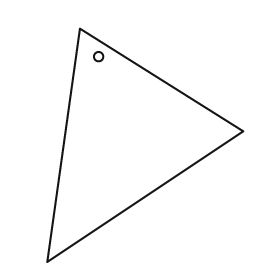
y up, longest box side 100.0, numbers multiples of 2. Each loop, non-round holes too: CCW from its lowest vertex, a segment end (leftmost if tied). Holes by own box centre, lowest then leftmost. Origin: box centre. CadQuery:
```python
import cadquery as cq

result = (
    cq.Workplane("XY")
    .moveTo(-42.0, -50.0)
    .lineTo(42.0, 6.0)
    .lineTo(-28.0, 50.0)
    .close()
    .moveTo(-20.0, 38.0)
    .circle(2.0)
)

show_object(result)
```